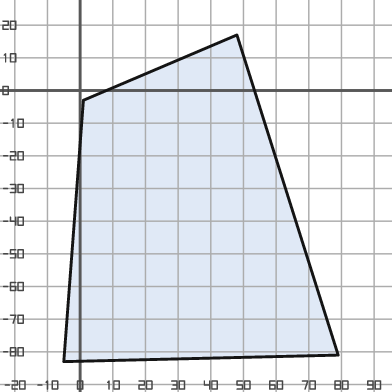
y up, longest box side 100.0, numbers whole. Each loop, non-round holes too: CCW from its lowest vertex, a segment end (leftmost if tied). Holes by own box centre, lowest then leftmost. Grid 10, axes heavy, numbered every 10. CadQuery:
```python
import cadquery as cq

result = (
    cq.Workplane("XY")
    .moveTo(-5.0, -83.0)
    .lineTo(79.0, -81.0)
    .lineTo(48.0, 17.0)
    .lineTo(1.0, -3.0)
    .close()
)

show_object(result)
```